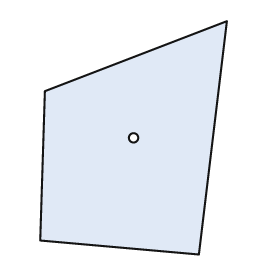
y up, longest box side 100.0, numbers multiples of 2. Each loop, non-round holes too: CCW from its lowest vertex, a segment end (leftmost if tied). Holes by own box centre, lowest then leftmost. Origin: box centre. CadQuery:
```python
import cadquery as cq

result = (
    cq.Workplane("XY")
    .moveTo(28.0, -50.0)
    .lineTo(40.0, 50.0)
    .lineTo(-38.0, 20.0)
    .lineTo(-40.0, -44.0)
    .close()
    .moveTo(0.0, 0.0)
    .circle(2.0)
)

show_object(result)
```